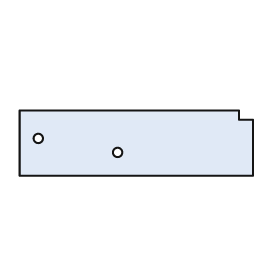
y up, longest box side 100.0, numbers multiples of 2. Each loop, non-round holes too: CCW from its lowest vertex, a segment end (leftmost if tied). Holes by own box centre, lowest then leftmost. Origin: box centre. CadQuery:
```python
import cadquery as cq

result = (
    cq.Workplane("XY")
    .moveTo(-50.0, -14.0)
    .lineTo(50.0, -14.0)
    .lineTo(50.0, 10.0)
    .lineTo(44.0, 10.0)
    .lineTo(44.0, 14.0)
    .lineTo(-50.0, 14.0)
    .close()
    .moveTo(-8.0, -4.0)
    .circle(2.0)
    .moveTo(-42.0, 2.0)
    .circle(2.0)
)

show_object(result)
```